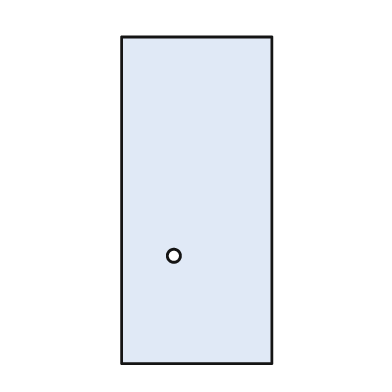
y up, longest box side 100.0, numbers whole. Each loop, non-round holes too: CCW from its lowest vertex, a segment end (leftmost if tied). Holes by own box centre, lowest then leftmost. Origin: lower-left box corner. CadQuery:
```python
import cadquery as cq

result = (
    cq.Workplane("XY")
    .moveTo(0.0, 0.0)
    .lineTo(46.0, 0.0)
    .lineTo(46.0, 100.0)
    .lineTo(0.0, 100.0)
    .close()
    .moveTo(16.0, 33.0)
    .circle(2.0)
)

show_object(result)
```